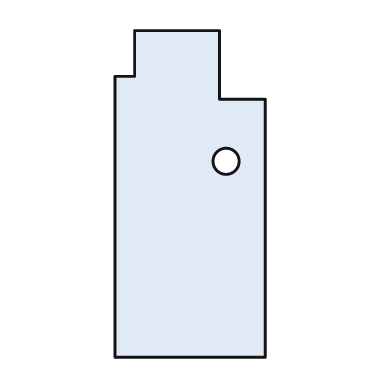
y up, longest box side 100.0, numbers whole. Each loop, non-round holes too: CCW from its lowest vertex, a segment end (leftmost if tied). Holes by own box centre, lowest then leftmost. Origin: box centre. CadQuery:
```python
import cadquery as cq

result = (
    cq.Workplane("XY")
    .moveTo(-23.0, -50.0)
    .lineTo(23.0, -50.0)
    .lineTo(23.0, 29.0)
    .lineTo(9.0, 29.0)
    .lineTo(9.0, 50.0)
    .lineTo(-17.0, 50.0)
    .lineTo(-17.0, 36.0)
    .lineTo(-23.0, 36.0)
    .close()
    .moveTo(11.0, 10.0)
    .circle(4.0)
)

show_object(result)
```